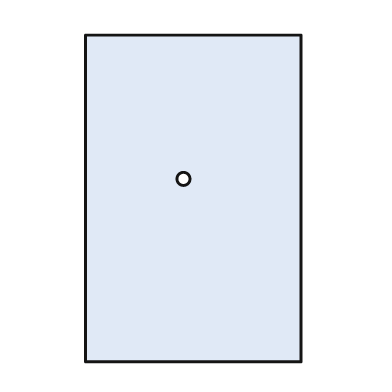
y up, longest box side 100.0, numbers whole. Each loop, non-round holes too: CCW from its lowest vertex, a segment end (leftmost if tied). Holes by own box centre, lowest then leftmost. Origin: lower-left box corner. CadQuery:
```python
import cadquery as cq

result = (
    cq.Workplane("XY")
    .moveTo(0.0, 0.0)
    .lineTo(66.0, 0.0)
    .lineTo(66.0, 100.0)
    .lineTo(0.0, 100.0)
    .close()
    .moveTo(30.0, 56.0)
    .circle(2.0)
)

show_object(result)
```